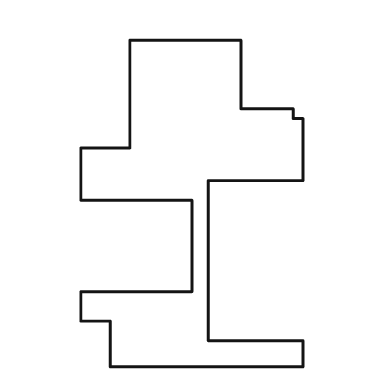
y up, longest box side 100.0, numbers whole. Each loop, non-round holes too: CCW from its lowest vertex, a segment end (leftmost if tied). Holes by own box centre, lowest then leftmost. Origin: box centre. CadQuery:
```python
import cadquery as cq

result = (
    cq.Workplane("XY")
    .moveTo(-25.0, -50.0)
    .lineTo(34.0, -50.0)
    .lineTo(34.0, -42.0)
    .lineTo(5.0, -42.0)
    .lineTo(5.0, 7.0)
    .lineTo(34.0, 7.0)
    .lineTo(34.0, 26.0)
    .lineTo(31.0, 26.0)
    .lineTo(31.0, 29.0)
    .lineTo(15.0, 29.0)
    .lineTo(15.0, 50.0)
    .lineTo(-19.0, 50.0)
    .lineTo(-19.0, 17.0)
    .lineTo(-34.0, 17.0)
    .lineTo(-34.0, 1.0)
    .lineTo(0.0, 1.0)
    .lineTo(0.0, -27.0)
    .lineTo(-34.0, -27.0)
    .lineTo(-34.0, -36.0)
    .lineTo(-25.0, -36.0)
    .close()
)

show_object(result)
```